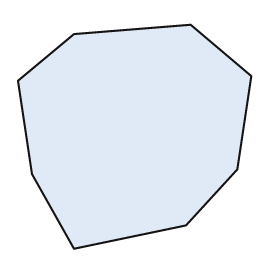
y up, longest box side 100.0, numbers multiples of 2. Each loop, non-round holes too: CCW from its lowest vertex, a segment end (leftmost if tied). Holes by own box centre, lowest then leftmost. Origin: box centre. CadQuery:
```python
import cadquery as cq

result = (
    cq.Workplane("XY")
    .moveTo(-26.0, -48.0)
    .lineTo(22.0, -38.0)
    .lineTo(44.0, -14.0)
    .lineTo(50.0, 26.0)
    .lineTo(24.0, 48.0)
    .lineTo(-26.0, 44.0)
    .lineTo(-50.0, 24.0)
    .lineTo(-44.0, -16.0)
    .close()
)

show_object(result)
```